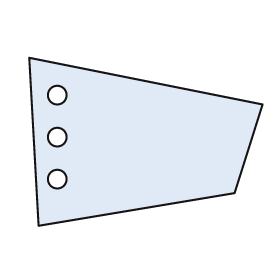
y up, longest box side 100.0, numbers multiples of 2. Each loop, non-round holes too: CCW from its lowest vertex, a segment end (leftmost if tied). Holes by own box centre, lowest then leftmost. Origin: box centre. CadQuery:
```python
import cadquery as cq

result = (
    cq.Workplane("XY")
    .moveTo(-46.0, -36.0)
    .lineTo(38.0, -22.0)
    .lineTo(50.0, 16.0)
    .lineTo(-50.0, 36.0)
    .close()
    .moveTo(-38.0, -16.0)
    .circle(4.0)
    .moveTo(-38.0, 2.0)
    .circle(4.0)
    .moveTo(-38.0, 20.0)
    .circle(4.0)
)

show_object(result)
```